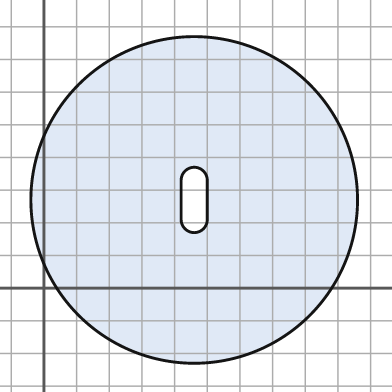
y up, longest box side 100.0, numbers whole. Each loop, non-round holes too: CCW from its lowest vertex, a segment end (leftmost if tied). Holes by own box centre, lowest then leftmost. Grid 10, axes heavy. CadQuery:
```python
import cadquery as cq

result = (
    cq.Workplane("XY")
    .moveTo(46.0, 27.0)
    .circle(50.0)
    .moveTo(42.0, 21.0)
    .threePointArc((46.0, 17.0), (50.0, 21.0))
    .lineTo(50.0, 33.0)
    .threePointArc((46.0, 37.0), (42.0, 33.0))
    .close()
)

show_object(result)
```